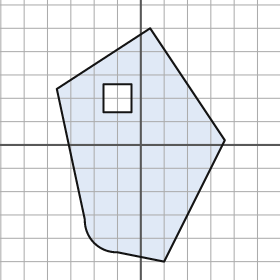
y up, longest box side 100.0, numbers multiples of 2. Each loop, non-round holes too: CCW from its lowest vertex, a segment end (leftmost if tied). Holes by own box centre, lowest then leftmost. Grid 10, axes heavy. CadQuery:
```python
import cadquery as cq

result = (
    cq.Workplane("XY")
    .moveTo(10.0, -50.0)
    .lineTo(36.0, 2.0)
    .lineTo(4.0, 50.0)
    .lineTo(-36.0, 24.0)
    .lineTo(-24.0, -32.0)
    .threePointArc((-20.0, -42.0), (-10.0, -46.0))
    .close()
    .moveTo(-16.0, 14.0)
    .lineTo(-4.0, 14.0)
    .lineTo(-4.0, 26.0)
    .lineTo(-16.0, 26.0)
    .close()
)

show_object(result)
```